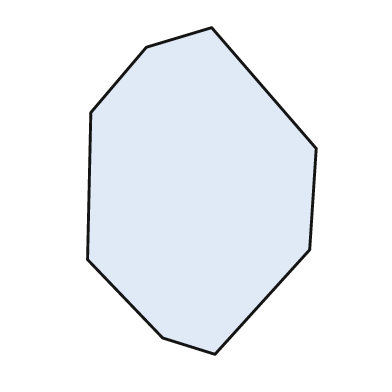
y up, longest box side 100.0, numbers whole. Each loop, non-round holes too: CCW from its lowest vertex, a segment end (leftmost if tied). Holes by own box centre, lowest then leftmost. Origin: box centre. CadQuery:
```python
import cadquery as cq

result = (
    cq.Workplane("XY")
    .moveTo(4.0, -50.0)
    .lineTo(33.0, -18.0)
    .lineTo(35.0, 13.0)
    .lineTo(3.0, 50.0)
    .lineTo(-17.0, 44.0)
    .lineTo(-34.0, 24.0)
    .lineTo(-35.0, -21.0)
    .lineTo(-12.0, -45.0)
    .close()
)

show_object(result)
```